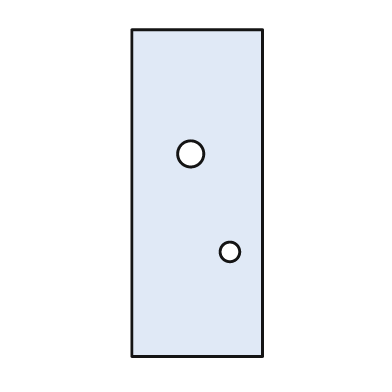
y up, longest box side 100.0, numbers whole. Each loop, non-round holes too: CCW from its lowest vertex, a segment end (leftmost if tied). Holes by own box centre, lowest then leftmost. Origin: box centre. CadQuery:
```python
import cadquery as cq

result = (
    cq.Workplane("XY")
    .moveTo(-20.0, -50.0)
    .lineTo(20.0, -50.0)
    .lineTo(20.0, 50.0)
    .lineTo(-20.0, 50.0)
    .close()
    .moveTo(10.0, -18.0)
    .circle(3.0)
    .moveTo(-2.0, 12.0)
    .circle(4.0)
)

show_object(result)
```